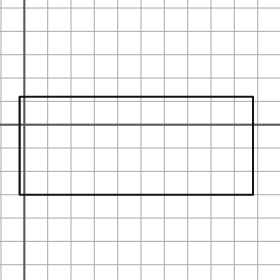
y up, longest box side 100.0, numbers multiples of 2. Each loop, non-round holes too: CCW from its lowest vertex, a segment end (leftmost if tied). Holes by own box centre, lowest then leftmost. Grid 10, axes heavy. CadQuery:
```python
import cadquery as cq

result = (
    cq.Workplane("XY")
    .moveTo(-2.0, -30.0)
    .lineTo(98.0, -30.0)
    .lineTo(98.0, 12.0)
    .lineTo(-2.0, 12.0)
    .close()
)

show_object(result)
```